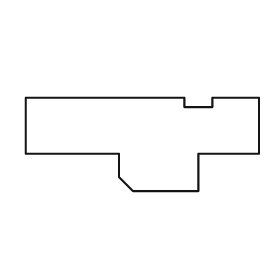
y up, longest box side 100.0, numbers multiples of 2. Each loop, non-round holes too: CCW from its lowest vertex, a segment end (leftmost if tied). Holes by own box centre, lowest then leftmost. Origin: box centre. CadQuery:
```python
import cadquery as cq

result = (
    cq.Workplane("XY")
    .moveTo(-4.0, -20.0)
    .lineTo(24.0, -20.0)
    .lineTo(24.0, -4.0)
    .lineTo(50.0, -4.0)
    .lineTo(50.0, 20.0)
    .lineTo(30.0, 20.0)
    .lineTo(30.0, 16.0)
    .lineTo(18.0, 16.0)
    .lineTo(18.0, 20.0)
    .lineTo(-50.0, 20.0)
    .lineTo(-50.0, -4.0)
    .lineTo(-10.0, -4.0)
    .lineTo(-10.0, -14.0)
    .close()
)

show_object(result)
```